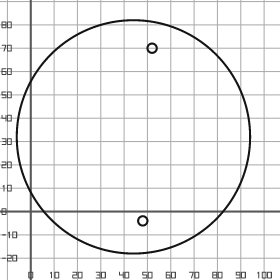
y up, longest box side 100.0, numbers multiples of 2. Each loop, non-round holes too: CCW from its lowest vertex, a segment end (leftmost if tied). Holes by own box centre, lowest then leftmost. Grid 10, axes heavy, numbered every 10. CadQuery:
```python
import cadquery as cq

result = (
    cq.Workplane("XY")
    .moveTo(44.0, 32.0)
    .circle(50.0)
    .moveTo(48.0, -4.0)
    .circle(2.0)
    .moveTo(52.0, 70.0)
    .circle(2.0)
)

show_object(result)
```